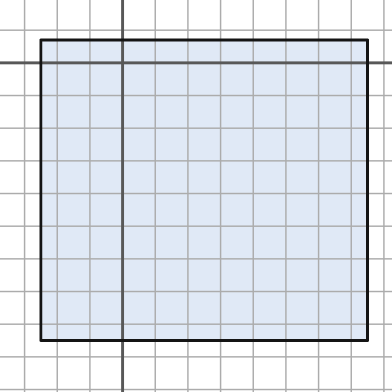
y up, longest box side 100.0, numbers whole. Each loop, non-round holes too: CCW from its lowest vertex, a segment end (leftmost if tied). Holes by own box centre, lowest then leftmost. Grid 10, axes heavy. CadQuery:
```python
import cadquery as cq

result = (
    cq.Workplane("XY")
    .moveTo(-25.0, -85.0)
    .lineTo(75.0, -85.0)
    .lineTo(75.0, 7.0)
    .lineTo(-25.0, 7.0)
    .close()
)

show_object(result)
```